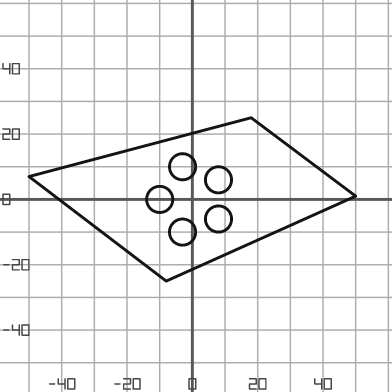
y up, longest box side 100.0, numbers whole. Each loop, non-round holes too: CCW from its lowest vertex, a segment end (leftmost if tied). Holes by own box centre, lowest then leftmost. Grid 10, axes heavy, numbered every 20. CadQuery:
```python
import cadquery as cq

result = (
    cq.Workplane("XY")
    .moveTo(-8.0, -25.0)
    .lineTo(50.0, 1.0)
    .lineTo(18.0, 25.0)
    .lineTo(-50.0, 7.0)
    .close()
    .moveTo(-3.0, -10.0)
    .circle(4.0)
    .moveTo(8.0, -6.0)
    .circle(4.0)
    .moveTo(-10.0, 0.0)
    .circle(4.0)
    .moveTo(8.0, 6.0)
    .circle(4.0)
    .moveTo(-3.0, 10.0)
    .circle(4.0)
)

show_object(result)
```